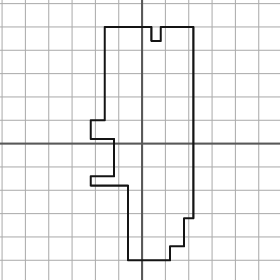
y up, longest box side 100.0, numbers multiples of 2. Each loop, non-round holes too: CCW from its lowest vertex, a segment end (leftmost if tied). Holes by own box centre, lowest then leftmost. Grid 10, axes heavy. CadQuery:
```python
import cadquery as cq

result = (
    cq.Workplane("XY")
    .moveTo(-6.0, -50.0)
    .lineTo(12.0, -50.0)
    .lineTo(12.0, -44.0)
    .lineTo(18.0, -44.0)
    .lineTo(18.0, -32.0)
    .lineTo(22.0, -32.0)
    .lineTo(22.0, 50.0)
    .lineTo(8.0, 50.0)
    .lineTo(8.0, 44.0)
    .lineTo(4.0, 44.0)
    .lineTo(4.0, 50.0)
    .lineTo(-16.0, 50.0)
    .lineTo(-16.0, 10.0)
    .lineTo(-22.0, 10.0)
    .lineTo(-22.0, 2.0)
    .lineTo(-12.0, 2.0)
    .lineTo(-12.0, -14.0)
    .lineTo(-22.0, -14.0)
    .lineTo(-22.0, -18.0)
    .lineTo(-6.0, -18.0)
    .close()
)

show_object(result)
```